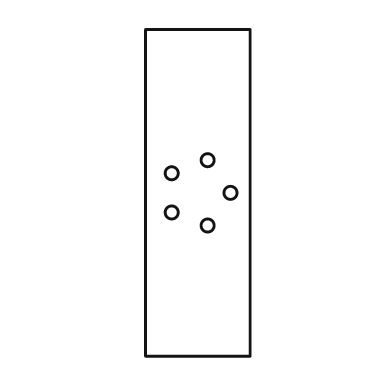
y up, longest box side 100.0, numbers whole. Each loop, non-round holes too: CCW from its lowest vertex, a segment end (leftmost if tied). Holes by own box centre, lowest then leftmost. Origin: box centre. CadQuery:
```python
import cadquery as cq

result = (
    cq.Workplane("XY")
    .moveTo(-16.0, -50.0)
    .lineTo(16.0, -50.0)
    .lineTo(16.0, 50.0)
    .lineTo(-16.0, 50.0)
    .close()
    .moveTo(3.0, -10.0)
    .circle(2.0)
    .moveTo(-8.0, -6.0)
    .circle(2.0)
    .moveTo(10.0, 0.0)
    .circle(2.0)
    .moveTo(-8.0, 6.0)
    .circle(2.0)
    .moveTo(3.0, 10.0)
    .circle(2.0)
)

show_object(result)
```